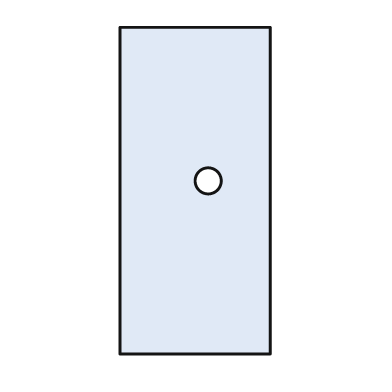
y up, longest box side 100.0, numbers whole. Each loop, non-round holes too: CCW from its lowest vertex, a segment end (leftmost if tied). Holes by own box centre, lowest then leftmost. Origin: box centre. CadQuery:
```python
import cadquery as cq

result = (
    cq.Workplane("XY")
    .moveTo(-23.0, -50.0)
    .lineTo(23.0, -50.0)
    .lineTo(23.0, 50.0)
    .lineTo(-23.0, 50.0)
    .close()
    .moveTo(4.0, 3.0)
    .circle(4.0)
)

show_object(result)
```